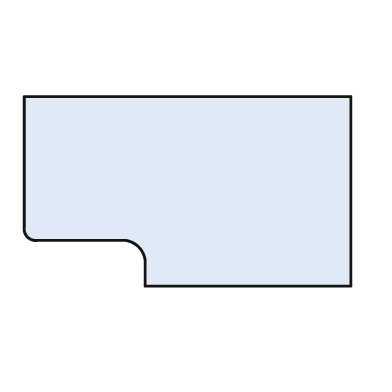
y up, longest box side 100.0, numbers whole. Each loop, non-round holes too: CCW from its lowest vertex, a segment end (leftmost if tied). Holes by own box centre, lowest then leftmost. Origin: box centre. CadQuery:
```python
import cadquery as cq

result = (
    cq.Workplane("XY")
    .moveTo(-13.0, -29.0)
    .lineTo(50.0, -29.0)
    .lineTo(50.0, 29.0)
    .lineTo(-50.0, 29.0)
    .lineTo(-50.0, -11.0)
    .threePointArc((-49.0, -14.0), (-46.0, -15.0))
    .lineTo(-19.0, -15.0)
    .threePointArc((-15.0, -17.0), (-13.0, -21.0))
    .close()
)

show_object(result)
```